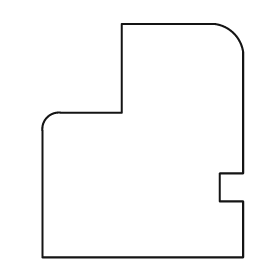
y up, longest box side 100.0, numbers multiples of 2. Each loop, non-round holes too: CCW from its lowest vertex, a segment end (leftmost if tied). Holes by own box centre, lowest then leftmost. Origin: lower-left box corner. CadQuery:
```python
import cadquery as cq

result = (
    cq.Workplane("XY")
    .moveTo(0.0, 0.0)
    .lineTo(86.0, 0.0)
    .lineTo(86.0, 24.0)
    .lineTo(76.0, 24.0)
    .lineTo(76.0, 36.0)
    .lineTo(86.0, 36.0)
    .lineTo(86.0, 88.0)
    .threePointArc((82.0, 96.0), (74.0, 100.0))
    .lineTo(34.0, 100.0)
    .lineTo(34.0, 62.0)
    .lineTo(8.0, 62.0)
    .threePointArc((2.0, 60.0), (0.0, 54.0))
    .close()
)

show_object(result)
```